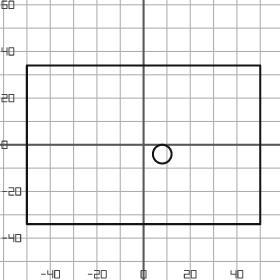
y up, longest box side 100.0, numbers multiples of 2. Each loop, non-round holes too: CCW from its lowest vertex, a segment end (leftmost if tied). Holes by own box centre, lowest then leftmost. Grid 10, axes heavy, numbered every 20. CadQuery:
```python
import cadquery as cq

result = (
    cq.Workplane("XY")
    .moveTo(-50.0, -34.0)
    .lineTo(50.0, -34.0)
    .lineTo(50.0, 34.0)
    .lineTo(-50.0, 34.0)
    .close()
    .moveTo(8.0, -4.0)
    .circle(4.0)
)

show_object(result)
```